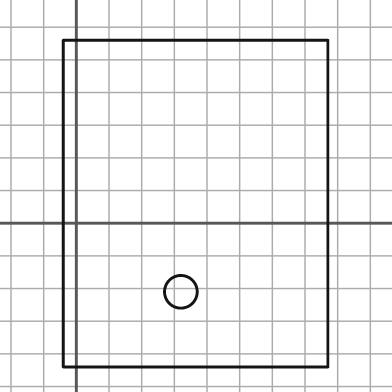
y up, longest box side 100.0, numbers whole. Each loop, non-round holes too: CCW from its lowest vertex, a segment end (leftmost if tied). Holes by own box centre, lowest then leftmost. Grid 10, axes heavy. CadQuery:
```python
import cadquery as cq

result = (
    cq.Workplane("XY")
    .moveTo(-4.0, -44.0)
    .lineTo(77.0, -44.0)
    .lineTo(77.0, 56.0)
    .lineTo(-4.0, 56.0)
    .close()
    .moveTo(32.0, -21.0)
    .circle(5.0)
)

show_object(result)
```